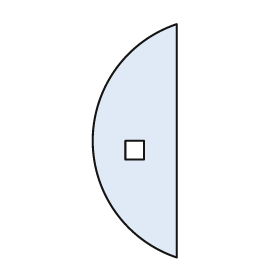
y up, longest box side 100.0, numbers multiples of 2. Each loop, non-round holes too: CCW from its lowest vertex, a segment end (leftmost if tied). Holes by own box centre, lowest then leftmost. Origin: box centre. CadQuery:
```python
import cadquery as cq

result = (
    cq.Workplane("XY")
    .moveTo(18.0, -50.0)
    .lineTo(18.0, 50.0)
    .threePointArc((-18.0, 0.0), (18.0, -50.0))
    .close()
    .moveTo(-4.0, -8.0)
    .lineTo(4.0, -8.0)
    .lineTo(4.0, 0.0)
    .lineTo(-4.0, 0.0)
    .close()
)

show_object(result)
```